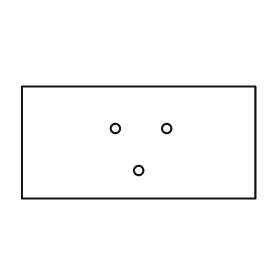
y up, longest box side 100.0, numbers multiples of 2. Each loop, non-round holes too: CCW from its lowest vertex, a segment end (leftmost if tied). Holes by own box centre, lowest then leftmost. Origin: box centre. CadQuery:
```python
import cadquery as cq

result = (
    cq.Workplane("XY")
    .moveTo(-50.0, -24.0)
    .lineTo(50.0, -24.0)
    .lineTo(50.0, 24.0)
    .lineTo(-50.0, 24.0)
    .close()
    .moveTo(0.0, -12.0)
    .circle(2.0)
    .moveTo(-10.0, 6.0)
    .circle(2.0)
    .moveTo(12.0, 6.0)
    .circle(2.0)
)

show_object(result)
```